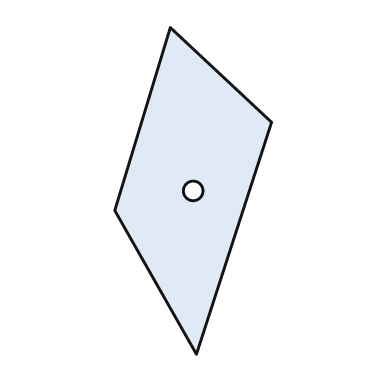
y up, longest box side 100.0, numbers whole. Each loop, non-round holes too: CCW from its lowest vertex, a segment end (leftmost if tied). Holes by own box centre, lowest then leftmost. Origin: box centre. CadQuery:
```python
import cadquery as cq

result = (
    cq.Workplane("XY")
    .moveTo(1.0, -50.0)
    .lineTo(24.0, 21.0)
    .lineTo(-7.0, 50.0)
    .lineTo(-24.0, -6.0)
    .close()
    .moveTo(0.0, 0.0)
    .circle(3.0)
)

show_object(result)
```